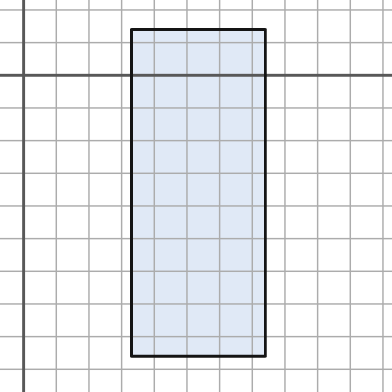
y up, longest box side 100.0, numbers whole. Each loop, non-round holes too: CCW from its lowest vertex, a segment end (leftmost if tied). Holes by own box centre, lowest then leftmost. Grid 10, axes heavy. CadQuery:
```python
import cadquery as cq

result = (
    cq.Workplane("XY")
    .moveTo(33.0, -86.0)
    .lineTo(74.0, -86.0)
    .lineTo(74.0, 14.0)
    .lineTo(33.0, 14.0)
    .close()
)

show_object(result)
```